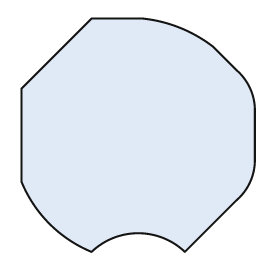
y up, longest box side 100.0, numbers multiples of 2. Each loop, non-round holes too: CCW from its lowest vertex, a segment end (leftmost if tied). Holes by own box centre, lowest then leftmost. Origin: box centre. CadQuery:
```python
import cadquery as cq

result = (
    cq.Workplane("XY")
    .moveTo(-20.0, -50.0)
    .threePointArc((0.0, -42.0), (20.0, -50.0))
    .lineTo(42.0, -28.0)
    .threePointArc((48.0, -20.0), (50.0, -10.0))
    .lineTo(50.0, 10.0)
    .threePointArc((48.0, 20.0), (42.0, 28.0))
    .lineTo(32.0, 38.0)
    .threePointArc((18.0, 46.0), (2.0, 50.0))
    .lineTo(-20.0, 50.0)
    .lineTo(-50.0, 20.0)
    .lineTo(-50.0, -20.0)
    .threePointArc((-38.0, -38.0), (-20.0, -50.0))
    .close()
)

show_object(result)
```